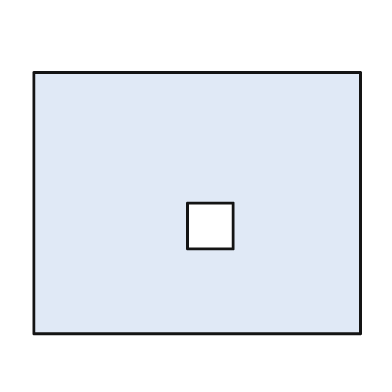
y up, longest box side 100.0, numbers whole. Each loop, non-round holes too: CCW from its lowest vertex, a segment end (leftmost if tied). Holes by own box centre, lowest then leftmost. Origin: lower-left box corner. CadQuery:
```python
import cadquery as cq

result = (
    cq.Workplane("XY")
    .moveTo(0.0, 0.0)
    .lineTo(100.0, 0.0)
    .lineTo(100.0, 80.0)
    .lineTo(0.0, 80.0)
    .close()
    .moveTo(47.0, 26.0)
    .lineTo(61.0, 26.0)
    .lineTo(61.0, 40.0)
    .lineTo(47.0, 40.0)
    .close()
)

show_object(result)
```